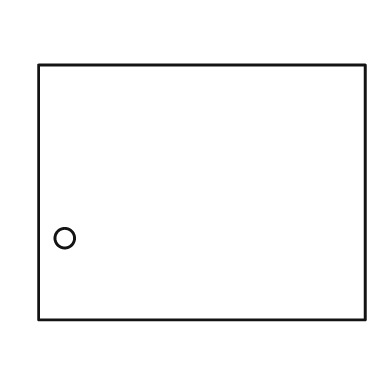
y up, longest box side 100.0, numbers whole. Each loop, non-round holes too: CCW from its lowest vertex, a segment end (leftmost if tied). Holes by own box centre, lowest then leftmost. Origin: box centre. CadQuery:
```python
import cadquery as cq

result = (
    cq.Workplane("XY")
    .moveTo(-50.0, -39.0)
    .lineTo(50.0, -39.0)
    .lineTo(50.0, 39.0)
    .lineTo(-50.0, 39.0)
    .close()
    .moveTo(-42.0, -14.0)
    .circle(3.0)
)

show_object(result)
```